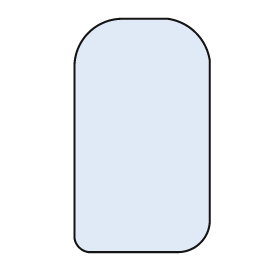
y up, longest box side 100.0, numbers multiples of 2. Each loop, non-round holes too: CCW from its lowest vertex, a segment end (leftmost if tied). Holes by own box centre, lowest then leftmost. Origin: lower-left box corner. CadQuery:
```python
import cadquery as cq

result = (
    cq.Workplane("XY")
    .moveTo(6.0, 0.0)
    .lineTo(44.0, 0.0)
    .threePointArc((54.0, 4.0), (58.0, 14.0))
    .lineTo(58.0, 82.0)
    .threePointArc((52.0, 94.0), (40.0, 100.0))
    .lineTo(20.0, 100.0)
    .threePointArc((6.0, 94.0), (0.0, 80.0))
    .lineTo(0.0, 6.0)
    .threePointArc((2.0, 2.0), (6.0, 0.0))
    .close()
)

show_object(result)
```